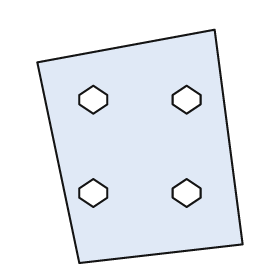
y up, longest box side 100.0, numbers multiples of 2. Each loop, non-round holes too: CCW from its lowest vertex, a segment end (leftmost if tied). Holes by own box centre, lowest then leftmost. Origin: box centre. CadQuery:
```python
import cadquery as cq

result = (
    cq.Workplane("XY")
    .moveTo(-26.0, -50.0)
    .lineTo(44.0, -42.0)
    .lineTo(32.0, 50.0)
    .lineTo(-44.0, 36.0)
    .close()
    .moveTo(-20.0, -26.0)
    .lineTo(-14.0, -22.0)
    .lineTo(-14.0, -18.0)
    .lineTo(-20.0, -14.0)
    .lineTo(-26.0, -18.0)
    .lineTo(-26.0, -22.0)
    .close()
    .moveTo(20.0, -26.0)
    .lineTo(26.0, -22.0)
    .lineTo(26.0, -18.0)
    .lineTo(20.0, -14.0)
    .lineTo(14.0, -18.0)
    .lineTo(14.0, -22.0)
    .close()
    .moveTo(-20.0, 14.0)
    .lineTo(-14.0, 18.0)
    .lineTo(-14.0, 22.0)
    .lineTo(-20.0, 26.0)
    .lineTo(-26.0, 22.0)
    .lineTo(-26.0, 18.0)
    .close()
    .moveTo(20.0, 14.0)
    .lineTo(26.0, 18.0)
    .lineTo(26.0, 22.0)
    .lineTo(20.0, 26.0)
    .lineTo(14.0, 22.0)
    .lineTo(14.0, 18.0)
    .close()
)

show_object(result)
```